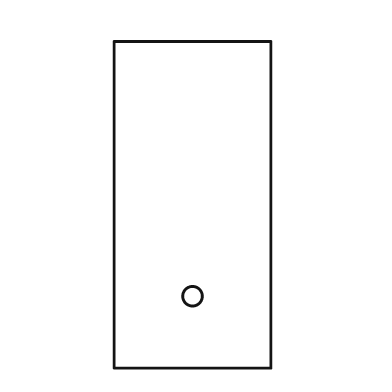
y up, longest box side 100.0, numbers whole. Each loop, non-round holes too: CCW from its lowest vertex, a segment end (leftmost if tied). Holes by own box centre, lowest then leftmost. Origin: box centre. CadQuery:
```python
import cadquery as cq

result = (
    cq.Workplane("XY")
    .moveTo(-24.0, -50.0)
    .lineTo(24.0, -50.0)
    .lineTo(24.0, 50.0)
    .lineTo(-24.0, 50.0)
    .close()
    .moveTo(0.0, -28.0)
    .circle(3.0)
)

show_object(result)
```